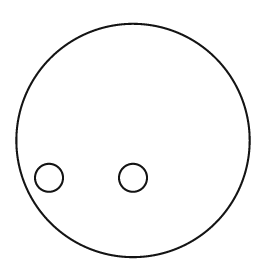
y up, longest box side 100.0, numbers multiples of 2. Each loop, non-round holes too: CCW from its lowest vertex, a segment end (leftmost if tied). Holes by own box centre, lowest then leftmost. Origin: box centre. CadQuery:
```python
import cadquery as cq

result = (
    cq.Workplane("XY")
    .moveTo(0.0, 0.0)
    .circle(50.0)
    .moveTo(-36.0, -16.0)
    .circle(6.0)
    .moveTo(0.0, -16.0)
    .circle(6.0)
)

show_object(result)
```